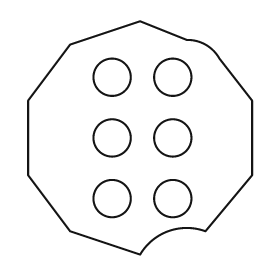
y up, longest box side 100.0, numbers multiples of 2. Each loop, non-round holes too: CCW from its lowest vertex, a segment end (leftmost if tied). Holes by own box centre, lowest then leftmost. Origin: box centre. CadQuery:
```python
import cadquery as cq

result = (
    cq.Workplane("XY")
    .moveTo(0.0, -50.0)
    .threePointArc((12.0, -40.0), (28.0, -40.0))
    .lineTo(48.0, -16.0)
    .lineTo(48.0, 16.0)
    .lineTo(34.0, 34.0)
    .threePointArc((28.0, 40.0), (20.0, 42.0))
    .lineTo(0.0, 50.0)
    .lineTo(-30.0, 40.0)
    .lineTo(-48.0, 16.0)
    .lineTo(-48.0, -16.0)
    .lineTo(-30.0, -40.0)
    .close()
    .moveTo(-12.0, -26.0)
    .circle(8.0)
    .moveTo(14.0, -26.0)
    .circle(8.0)
    .moveTo(-12.0, 0.0)
    .circle(8.0)
    .moveTo(14.0, 0.0)
    .circle(8.0)
    .moveTo(-12.0, 26.0)
    .circle(8.0)
    .moveTo(14.0, 26.0)
    .circle(8.0)
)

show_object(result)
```